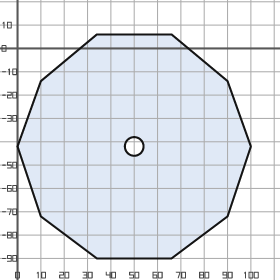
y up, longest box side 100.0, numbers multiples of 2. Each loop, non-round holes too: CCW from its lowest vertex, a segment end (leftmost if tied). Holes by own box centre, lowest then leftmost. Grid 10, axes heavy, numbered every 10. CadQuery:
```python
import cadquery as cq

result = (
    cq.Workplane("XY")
    .moveTo(34.0, -90.0)
    .lineTo(66.0, -90.0)
    .lineTo(90.0, -72.0)
    .lineTo(100.0, -42.0)
    .lineTo(90.0, -14.0)
    .lineTo(66.0, 6.0)
    .lineTo(34.0, 6.0)
    .lineTo(10.0, -14.0)
    .lineTo(0.0, -42.0)
    .lineTo(10.0, -72.0)
    .close()
    .moveTo(50.0, -42.0)
    .circle(4.0)
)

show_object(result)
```